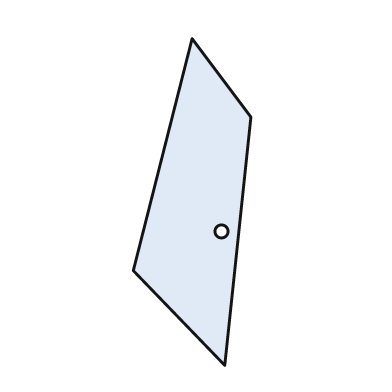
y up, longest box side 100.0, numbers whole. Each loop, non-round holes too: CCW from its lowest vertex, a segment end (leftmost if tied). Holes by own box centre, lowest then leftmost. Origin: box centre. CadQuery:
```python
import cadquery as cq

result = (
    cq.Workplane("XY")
    .moveTo(10.0, -50.0)
    .lineTo(18.0, 26.0)
    .lineTo(0.0, 50.0)
    .lineTo(-18.0, -21.0)
    .close()
    .moveTo(9.0, -9.0)
    .circle(2.0)
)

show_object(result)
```